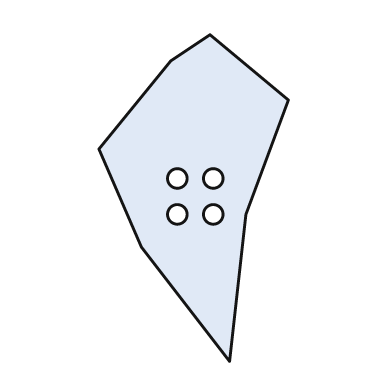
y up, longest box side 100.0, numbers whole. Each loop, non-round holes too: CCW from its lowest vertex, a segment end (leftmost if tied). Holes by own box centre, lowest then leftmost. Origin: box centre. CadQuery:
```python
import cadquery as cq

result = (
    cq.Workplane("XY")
    .moveTo(11.0, -50.0)
    .lineTo(16.0, -5.0)
    .lineTo(29.0, 30.0)
    .lineTo(5.0, 50.0)
    .lineTo(-7.0, 42.0)
    .lineTo(-29.0, 15.0)
    .lineTo(-16.0, -15.0)
    .close()
    .moveTo(-5.0, -5.0)
    .circle(3.0)
    .moveTo(6.0, -5.0)
    .circle(3.0)
    .moveTo(-5.0, 6.0)
    .circle(3.0)
    .moveTo(6.0, 6.0)
    .circle(3.0)
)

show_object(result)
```